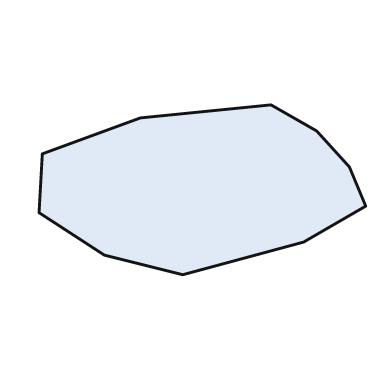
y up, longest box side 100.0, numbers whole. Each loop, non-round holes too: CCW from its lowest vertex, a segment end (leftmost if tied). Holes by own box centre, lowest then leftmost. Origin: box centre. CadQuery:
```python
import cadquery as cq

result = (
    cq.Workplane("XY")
    .moveTo(-6.0, -26.0)
    .lineTo(31.0, -16.0)
    .lineTo(50.0, -5.0)
    .lineTo(45.0, 7.0)
    .lineTo(35.0, 18.0)
    .lineTo(21.0, 26.0)
    .lineTo(-19.0, 22.0)
    .lineTo(-49.0, 11.0)
    .lineTo(-50.0, -7.0)
    .lineTo(-30.0, -20.0)
    .close()
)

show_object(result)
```